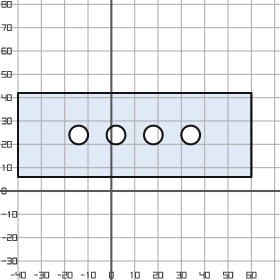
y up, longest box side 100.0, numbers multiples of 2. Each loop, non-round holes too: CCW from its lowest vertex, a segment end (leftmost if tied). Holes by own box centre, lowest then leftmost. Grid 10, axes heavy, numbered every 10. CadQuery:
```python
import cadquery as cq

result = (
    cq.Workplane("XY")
    .moveTo(-40.0, 6.0)
    .lineTo(60.0, 6.0)
    .lineTo(60.0, 42.0)
    .lineTo(-40.0, 42.0)
    .close()
    .moveTo(-14.0, 24.0)
    .circle(4.0)
    .moveTo(2.0, 24.0)
    .circle(4.0)
    .moveTo(18.0, 24.0)
    .circle(4.0)
    .moveTo(34.0, 24.0)
    .circle(4.0)
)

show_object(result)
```